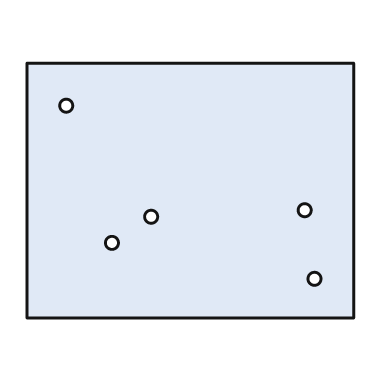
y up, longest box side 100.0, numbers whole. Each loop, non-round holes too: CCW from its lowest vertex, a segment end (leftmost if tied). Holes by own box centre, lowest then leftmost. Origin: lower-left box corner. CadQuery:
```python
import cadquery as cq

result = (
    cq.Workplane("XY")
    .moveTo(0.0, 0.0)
    .lineTo(100.0, 0.0)
    .lineTo(100.0, 78.0)
    .lineTo(0.0, 78.0)
    .close()
    .moveTo(88.0, 12.0)
    .circle(2.0)
    .moveTo(26.0, 23.0)
    .circle(2.0)
    .moveTo(38.0, 31.0)
    .circle(2.0)
    .moveTo(85.0, 33.0)
    .circle(2.0)
    .moveTo(12.0, 65.0)
    .circle(2.0)
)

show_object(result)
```